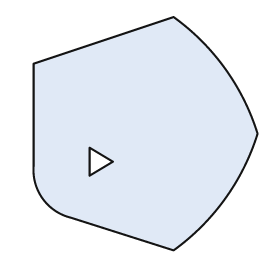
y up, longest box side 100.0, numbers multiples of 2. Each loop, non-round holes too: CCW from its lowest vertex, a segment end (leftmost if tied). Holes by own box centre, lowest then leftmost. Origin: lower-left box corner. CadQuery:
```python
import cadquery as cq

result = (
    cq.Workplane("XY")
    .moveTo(60.0, 0.0)
    .threePointArc((82.0, 22.0), (96.0, 50.0))
    .threePointArc((82.0, 78.0), (60.0, 100.0))
    .lineTo(0.0, 80.0)
    .lineTo(0.0, 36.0)
    .threePointArc((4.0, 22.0), (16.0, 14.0))
    .close()
    .moveTo(24.0, 32.0)
    .lineTo(34.0, 38.0)
    .lineTo(24.0, 44.0)
    .close()
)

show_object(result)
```